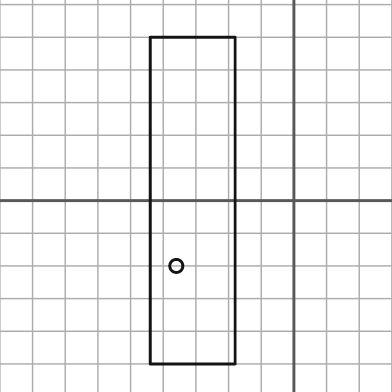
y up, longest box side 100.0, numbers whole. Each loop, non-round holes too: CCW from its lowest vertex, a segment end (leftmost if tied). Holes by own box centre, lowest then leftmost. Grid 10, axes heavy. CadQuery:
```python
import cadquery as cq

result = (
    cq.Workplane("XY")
    .moveTo(-44.0, -50.0)
    .lineTo(-18.0, -50.0)
    .lineTo(-18.0, 50.0)
    .lineTo(-44.0, 50.0)
    .close()
    .moveTo(-36.0, -20.0)
    .circle(2.0)
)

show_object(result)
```